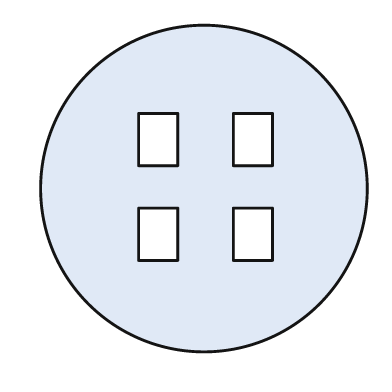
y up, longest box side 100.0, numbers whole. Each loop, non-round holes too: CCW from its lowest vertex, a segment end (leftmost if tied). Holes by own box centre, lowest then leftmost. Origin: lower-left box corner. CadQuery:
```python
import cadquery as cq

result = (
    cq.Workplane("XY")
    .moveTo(50.0, 50.0)
    .circle(50.0)
    .moveTo(30.0, 28.0)
    .lineTo(42.0, 28.0)
    .lineTo(42.0, 44.0)
    .lineTo(30.0, 44.0)
    .close()
    .moveTo(59.0, 28.0)
    .lineTo(71.0, 28.0)
    .lineTo(71.0, 44.0)
    .lineTo(59.0, 44.0)
    .close()
    .moveTo(30.0, 57.0)
    .lineTo(42.0, 57.0)
    .lineTo(42.0, 73.0)
    .lineTo(30.0, 73.0)
    .close()
    .moveTo(59.0, 57.0)
    .lineTo(71.0, 57.0)
    .lineTo(71.0, 73.0)
    .lineTo(59.0, 73.0)
    .close()
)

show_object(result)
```